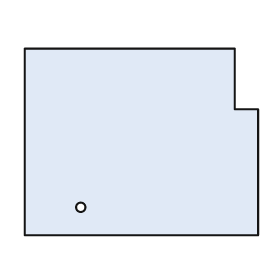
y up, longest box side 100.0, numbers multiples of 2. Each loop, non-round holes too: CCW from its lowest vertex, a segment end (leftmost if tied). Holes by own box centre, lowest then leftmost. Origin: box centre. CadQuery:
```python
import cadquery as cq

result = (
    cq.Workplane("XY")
    .moveTo(-50.0, -40.0)
    .lineTo(50.0, -40.0)
    .lineTo(50.0, 14.0)
    .lineTo(40.0, 14.0)
    .lineTo(40.0, 40.0)
    .lineTo(-50.0, 40.0)
    .close()
    .moveTo(-26.0, -28.0)
    .circle(2.0)
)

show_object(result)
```